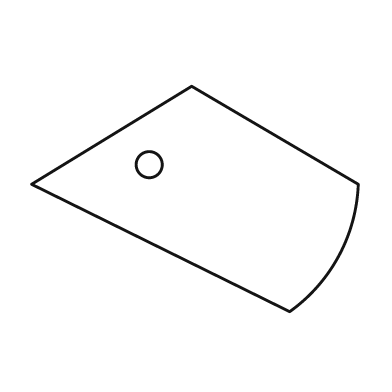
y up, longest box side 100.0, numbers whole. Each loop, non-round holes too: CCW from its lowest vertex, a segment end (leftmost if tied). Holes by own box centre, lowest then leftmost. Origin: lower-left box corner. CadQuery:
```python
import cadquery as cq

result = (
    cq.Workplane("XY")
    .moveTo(79.0, 0.0)
    .threePointArc((94.0, 17.0), (100.0, 39.0))
    .lineTo(49.0, 69.0)
    .lineTo(0.0, 39.0)
    .close()
    .moveTo(36.0, 45.0)
    .circle(4.0)
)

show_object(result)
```